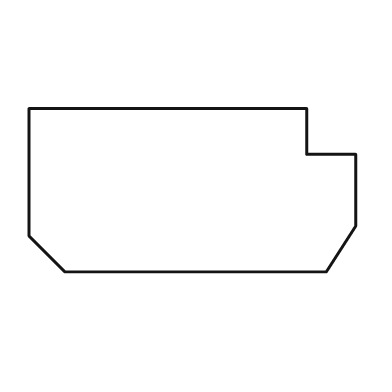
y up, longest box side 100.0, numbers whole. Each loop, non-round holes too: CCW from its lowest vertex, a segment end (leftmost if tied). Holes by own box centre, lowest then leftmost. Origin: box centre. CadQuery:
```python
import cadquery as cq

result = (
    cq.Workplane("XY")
    .moveTo(-39.0, -25.0)
    .lineTo(41.0, -25.0)
    .lineTo(50.0, -11.0)
    .lineTo(50.0, 11.0)
    .lineTo(35.0, 11.0)
    .lineTo(35.0, 25.0)
    .lineTo(-50.0, 25.0)
    .lineTo(-50.0, -14.0)
    .close()
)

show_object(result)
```